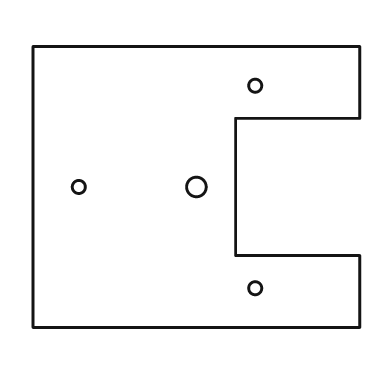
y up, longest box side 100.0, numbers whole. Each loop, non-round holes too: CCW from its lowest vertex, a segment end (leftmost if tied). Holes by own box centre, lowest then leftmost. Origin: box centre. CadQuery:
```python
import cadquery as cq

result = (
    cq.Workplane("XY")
    .moveTo(-50.0, -43.0)
    .lineTo(50.0, -43.0)
    .lineTo(50.0, -21.0)
    .lineTo(12.0, -21.0)
    .lineTo(12.0, 21.0)
    .lineTo(50.0, 21.0)
    .lineTo(50.0, 43.0)
    .lineTo(-50.0, 43.0)
    .close()
    .moveTo(18.0, -31.0)
    .circle(2.0)
    .moveTo(-36.0, 0.0)
    .circle(2.0)
    .moveTo(0.0, 0.0)
    .circle(3.0)
    .moveTo(18.0, 31.0)
    .circle(2.0)
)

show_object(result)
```